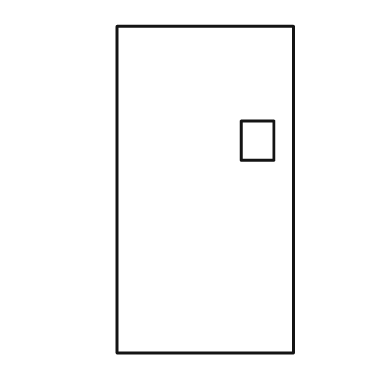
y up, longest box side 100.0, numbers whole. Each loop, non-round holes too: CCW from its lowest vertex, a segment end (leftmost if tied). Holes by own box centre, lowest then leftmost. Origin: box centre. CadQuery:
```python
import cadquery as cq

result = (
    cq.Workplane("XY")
    .moveTo(-27.0, -50.0)
    .lineTo(27.0, -50.0)
    .lineTo(27.0, 50.0)
    .lineTo(-27.0, 50.0)
    .close()
    .moveTo(11.0, 9.0)
    .lineTo(21.0, 9.0)
    .lineTo(21.0, 21.0)
    .lineTo(11.0, 21.0)
    .close()
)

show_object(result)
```